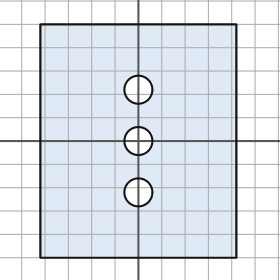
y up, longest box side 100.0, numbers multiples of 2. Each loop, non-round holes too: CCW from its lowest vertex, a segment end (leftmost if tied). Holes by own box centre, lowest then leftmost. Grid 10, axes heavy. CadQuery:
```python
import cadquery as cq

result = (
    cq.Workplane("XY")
    .moveTo(-42.0, -50.0)
    .lineTo(42.0, -50.0)
    .lineTo(42.0, 50.0)
    .lineTo(-42.0, 50.0)
    .close()
    .moveTo(0.0, -22.0)
    .circle(6.0)
    .moveTo(0.0, 0.0)
    .circle(6.0)
    .moveTo(0.0, 22.0)
    .circle(6.0)
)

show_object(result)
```